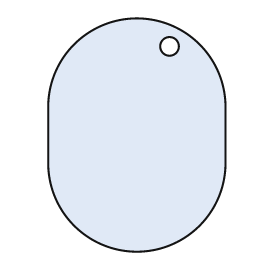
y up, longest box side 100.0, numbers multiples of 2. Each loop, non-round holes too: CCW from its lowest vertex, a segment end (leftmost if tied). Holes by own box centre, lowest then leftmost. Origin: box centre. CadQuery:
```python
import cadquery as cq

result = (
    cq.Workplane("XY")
    .moveTo(-38.0, -12.0)
    .threePointArc((0.0, -50.0), (38.0, -12.0))
    .lineTo(38.0, 12.0)
    .threePointArc((0.0, 50.0), (-38.0, 12.0))
    .close()
    .moveTo(14.0, 38.0)
    .circle(4.0)
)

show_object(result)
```